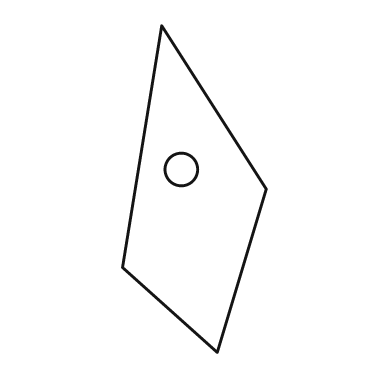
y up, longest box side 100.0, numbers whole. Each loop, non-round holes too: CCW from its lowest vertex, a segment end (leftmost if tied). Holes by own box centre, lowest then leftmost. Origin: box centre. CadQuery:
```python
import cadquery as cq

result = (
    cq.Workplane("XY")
    .moveTo(7.0, -50.0)
    .lineTo(22.0, 0.0)
    .lineTo(-10.0, 50.0)
    .lineTo(-22.0, -24.0)
    .close()
    .moveTo(-4.0, 6.0)
    .circle(5.0)
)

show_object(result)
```